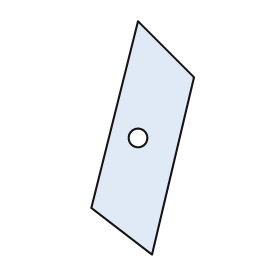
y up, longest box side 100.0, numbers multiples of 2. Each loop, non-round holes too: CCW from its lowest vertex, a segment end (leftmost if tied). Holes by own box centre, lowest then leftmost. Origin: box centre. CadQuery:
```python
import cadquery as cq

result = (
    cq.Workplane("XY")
    .moveTo(4.0, -50.0)
    .lineTo(22.0, 26.0)
    .lineTo(-2.0, 50.0)
    .lineTo(-22.0, -30.0)
    .close()
    .moveTo(-2.0, 0.0)
    .circle(4.0)
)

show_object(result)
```